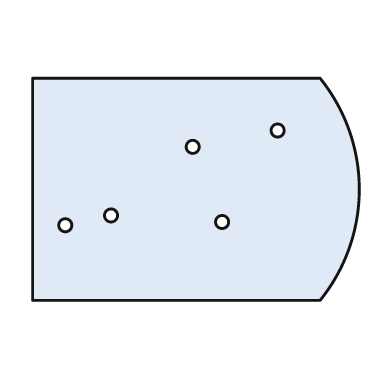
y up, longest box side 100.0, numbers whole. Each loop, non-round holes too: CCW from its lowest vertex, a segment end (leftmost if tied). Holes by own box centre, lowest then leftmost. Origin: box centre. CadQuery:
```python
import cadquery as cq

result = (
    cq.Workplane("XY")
    .moveTo(-50.0, -34.0)
    .lineTo(38.0, -34.0)
    .threePointArc((50.0, 0.0), (38.0, 34.0))
    .lineTo(-50.0, 34.0)
    .close()
    .moveTo(-40.0, -11.0)
    .circle(2.0)
    .moveTo(8.0, -10.0)
    .circle(2.0)
    .moveTo(-26.0, -8.0)
    .circle(2.0)
    .moveTo(-1.0, 13.0)
    .circle(2.0)
    .moveTo(25.0, 18.0)
    .circle(2.0)
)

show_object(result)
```